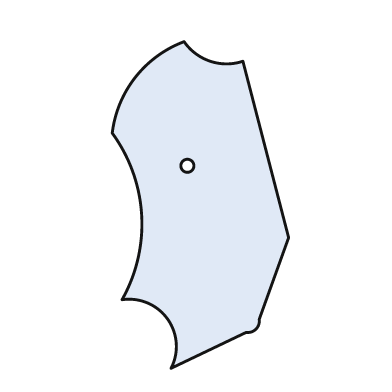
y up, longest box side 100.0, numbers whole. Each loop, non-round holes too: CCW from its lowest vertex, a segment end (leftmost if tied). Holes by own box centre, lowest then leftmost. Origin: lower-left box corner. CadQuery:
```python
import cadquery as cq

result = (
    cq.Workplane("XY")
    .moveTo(18.0, 0.0)
    .lineTo(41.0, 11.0)
    .threePointArc((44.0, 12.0), (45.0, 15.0))
    .lineTo(54.0, 40.0)
    .lineTo(40.0, 94.0)
    .threePointArc((30.0, 94.0), (22.0, 100.0))
    .threePointArc((7.0, 89.0), (0.0, 72.0))
    .threePointArc((9.0, 47.0), (3.0, 21.0))
    .threePointArc((17.0, 15.0), (18.0, 0.0))
    .close()
    .moveTo(23.0, 62.0)
    .circle(2.0)
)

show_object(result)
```